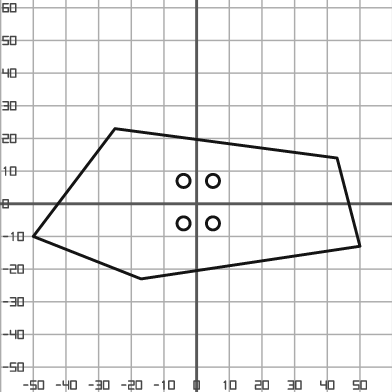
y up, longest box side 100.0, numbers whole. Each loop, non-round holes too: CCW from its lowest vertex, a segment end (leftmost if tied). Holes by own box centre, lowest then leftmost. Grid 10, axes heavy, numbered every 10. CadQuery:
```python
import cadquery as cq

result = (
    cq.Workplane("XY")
    .moveTo(-17.0, -23.0)
    .lineTo(50.0, -13.0)
    .lineTo(43.0, 14.0)
    .lineTo(-25.0, 23.0)
    .lineTo(-50.0, -10.0)
    .close()
    .moveTo(-4.0, -6.0)
    .circle(2.0)
    .moveTo(5.0, -6.0)
    .circle(2.0)
    .moveTo(-4.0, 7.0)
    .circle(2.0)
    .moveTo(5.0, 7.0)
    .circle(2.0)
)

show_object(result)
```